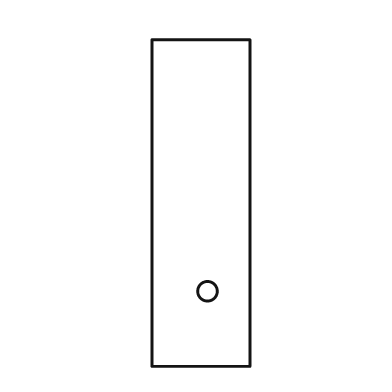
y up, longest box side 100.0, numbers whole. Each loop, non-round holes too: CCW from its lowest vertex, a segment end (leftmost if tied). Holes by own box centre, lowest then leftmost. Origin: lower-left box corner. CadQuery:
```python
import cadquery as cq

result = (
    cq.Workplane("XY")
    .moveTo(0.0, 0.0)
    .lineTo(30.0, 0.0)
    .lineTo(30.0, 100.0)
    .lineTo(0.0, 100.0)
    .close()
    .moveTo(17.0, 23.0)
    .circle(3.0)
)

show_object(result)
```